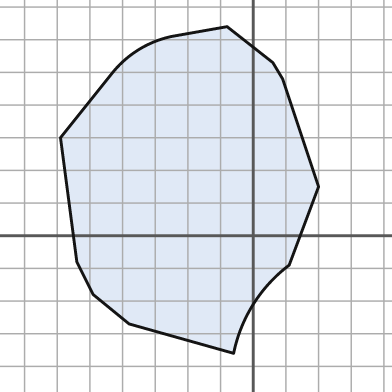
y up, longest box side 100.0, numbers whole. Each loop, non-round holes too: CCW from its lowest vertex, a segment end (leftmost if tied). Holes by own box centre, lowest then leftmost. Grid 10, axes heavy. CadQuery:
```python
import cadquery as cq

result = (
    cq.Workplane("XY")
    .moveTo(-6.0, -36.0)
    .threePointArc((0.0, -21.0), (11.0, -9.0))
    .lineTo(20.0, 15.0)
    .lineTo(9.0, 48.0)
    .lineTo(6.0, 53.0)
    .lineTo(-8.0, 64.0)
    .lineTo(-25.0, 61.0)
    .threePointArc((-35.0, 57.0), (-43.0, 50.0))
    .lineTo(-59.0, 30.0)
    .lineTo(-54.0, -8.0)
    .lineTo(-49.0, -18.0)
    .lineTo(-38.0, -27.0)
    .close()
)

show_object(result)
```